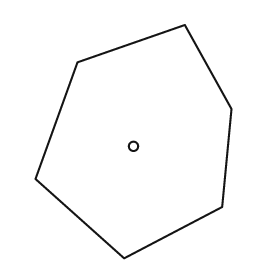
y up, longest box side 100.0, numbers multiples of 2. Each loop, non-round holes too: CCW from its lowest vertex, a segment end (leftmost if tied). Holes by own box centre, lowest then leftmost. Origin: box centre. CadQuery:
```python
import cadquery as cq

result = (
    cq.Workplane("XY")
    .moveTo(-4.0, -50.0)
    .lineTo(38.0, -28.0)
    .lineTo(42.0, 14.0)
    .lineTo(22.0, 50.0)
    .lineTo(-24.0, 34.0)
    .lineTo(-42.0, -16.0)
    .close()
    .moveTo(0.0, -2.0)
    .circle(2.0)
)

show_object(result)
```